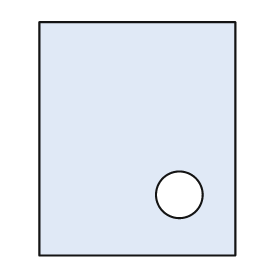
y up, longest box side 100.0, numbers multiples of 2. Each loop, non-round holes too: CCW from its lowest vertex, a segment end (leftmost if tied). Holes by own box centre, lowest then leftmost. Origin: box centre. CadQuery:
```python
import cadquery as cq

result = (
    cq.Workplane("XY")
    .moveTo(-42.0, -50.0)
    .lineTo(42.0, -50.0)
    .lineTo(42.0, 50.0)
    .lineTo(-42.0, 50.0)
    .close()
    .moveTo(18.0, -24.0)
    .circle(10.0)
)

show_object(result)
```